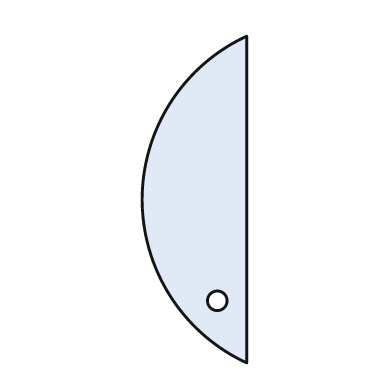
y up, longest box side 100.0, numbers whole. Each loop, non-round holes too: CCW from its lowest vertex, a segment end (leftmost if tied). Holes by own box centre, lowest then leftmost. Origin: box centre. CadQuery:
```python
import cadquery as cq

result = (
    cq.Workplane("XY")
    .moveTo(16.0, -50.0)
    .lineTo(16.0, 50.0)
    .threePointArc((-16.0, 0.0), (16.0, -50.0))
    .close()
    .moveTo(7.0, -31.0)
    .circle(3.0)
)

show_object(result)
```